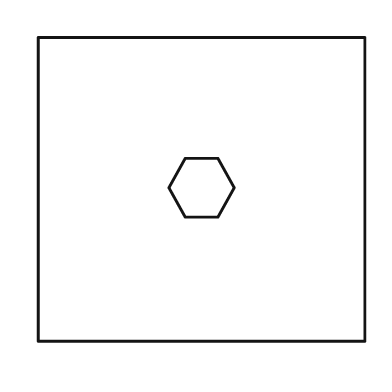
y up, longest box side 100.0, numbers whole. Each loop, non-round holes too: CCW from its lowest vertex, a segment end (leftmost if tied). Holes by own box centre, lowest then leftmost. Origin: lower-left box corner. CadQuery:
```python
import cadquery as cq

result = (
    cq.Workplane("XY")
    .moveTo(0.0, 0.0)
    .lineTo(100.0, 0.0)
    .lineTo(100.0, 93.0)
    .lineTo(0.0, 93.0)
    .close()
    .moveTo(45.0, 38.0)
    .lineTo(55.0, 38.0)
    .lineTo(60.0, 47.0)
    .lineTo(55.0, 56.0)
    .lineTo(45.0, 56.0)
    .lineTo(40.0, 47.0)
    .close()
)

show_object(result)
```